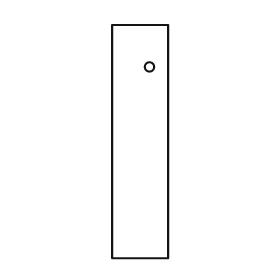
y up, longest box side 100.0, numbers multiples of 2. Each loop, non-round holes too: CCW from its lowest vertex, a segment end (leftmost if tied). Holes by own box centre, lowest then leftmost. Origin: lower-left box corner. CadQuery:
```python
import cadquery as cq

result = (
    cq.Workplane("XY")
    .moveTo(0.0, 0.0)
    .lineTo(24.0, 0.0)
    .lineTo(24.0, 100.0)
    .lineTo(0.0, 100.0)
    .close()
    .moveTo(16.0, 82.0)
    .circle(2.0)
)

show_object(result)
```